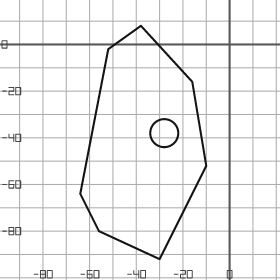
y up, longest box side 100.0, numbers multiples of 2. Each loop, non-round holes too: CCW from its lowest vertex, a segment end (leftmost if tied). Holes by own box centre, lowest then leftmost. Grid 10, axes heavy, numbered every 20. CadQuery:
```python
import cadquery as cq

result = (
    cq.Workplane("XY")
    .moveTo(-30.0, -92.0)
    .lineTo(-10.0, -52.0)
    .lineTo(-16.0, -16.0)
    .lineTo(-38.0, 8.0)
    .lineTo(-52.0, -2.0)
    .lineTo(-64.0, -64.0)
    .lineTo(-56.0, -80.0)
    .close()
    .moveTo(-28.0, -38.0)
    .circle(6.0)
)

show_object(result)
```